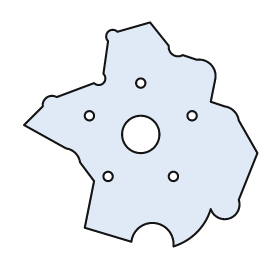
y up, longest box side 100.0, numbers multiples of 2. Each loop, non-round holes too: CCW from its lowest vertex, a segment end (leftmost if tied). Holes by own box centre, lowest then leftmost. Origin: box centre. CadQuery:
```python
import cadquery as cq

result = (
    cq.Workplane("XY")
    .moveTo(14.0, -48.0)
    .threePointArc((24.0, -42.0), (30.0, -32.0))
    .threePointArc((38.0, -36.0), (42.0, -28.0))
    .lineTo(50.0, -8.0)
    .lineTo(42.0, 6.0)
    .threePointArc((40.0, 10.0), (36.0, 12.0))
    .lineTo(30.0, 14.0)
    .lineTo(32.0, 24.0)
    .threePointArc((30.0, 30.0), (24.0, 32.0))
    .lineTo(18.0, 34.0)
    .threePointArc((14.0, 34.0), (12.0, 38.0))
    .lineTo(4.0, 48.0)
    .lineTo(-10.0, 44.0)
    .threePointArc((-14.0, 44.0), (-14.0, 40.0))
    .lineTo(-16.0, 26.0)
    .threePointArc((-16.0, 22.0), (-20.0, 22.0))
    .lineTo(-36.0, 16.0)
    .threePointArc((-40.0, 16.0), (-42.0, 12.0))
    .lineTo(-50.0, 4.0)
    .lineTo(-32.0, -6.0)
    .threePointArc((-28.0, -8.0), (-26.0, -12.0))
    .lineTo(-20.0, -20.0)
    .lineTo(-24.0, -40.0)
    .lineTo(-4.0, -46.0)
    .threePointArc((6.0, -38.0), (14.0, -48.0))
    .close()
    .moveTo(-14.0, -18.0)
    .circle(2.0)
    .moveTo(14.0, -18.0)
    .circle(2.0)
    .moveTo(0.0, 0.0)
    .circle(8.0)
    .moveTo(-22.0, 8.0)
    .circle(2.0)
    .moveTo(22.0, 8.0)
    .circle(2.0)
    .moveTo(0.0, 22.0)
    .circle(2.0)
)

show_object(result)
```